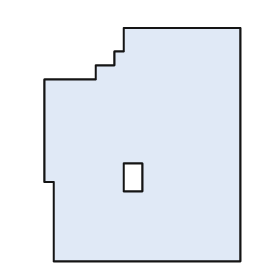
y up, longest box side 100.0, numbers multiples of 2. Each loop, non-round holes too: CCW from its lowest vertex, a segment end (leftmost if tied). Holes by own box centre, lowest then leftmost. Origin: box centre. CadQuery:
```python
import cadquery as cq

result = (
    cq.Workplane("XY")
    .moveTo(-38.0, -50.0)
    .lineTo(42.0, -50.0)
    .lineTo(42.0, 50.0)
    .lineTo(-8.0, 50.0)
    .lineTo(-8.0, 40.0)
    .lineTo(-12.0, 40.0)
    .lineTo(-12.0, 34.0)
    .lineTo(-20.0, 34.0)
    .lineTo(-20.0, 28.0)
    .lineTo(-42.0, 28.0)
    .lineTo(-42.0, -16.0)
    .lineTo(-38.0, -16.0)
    .close()
    .moveTo(-8.0, -20.0)
    .lineTo(0.0, -20.0)
    .lineTo(0.0, -8.0)
    .lineTo(-8.0, -8.0)
    .close()
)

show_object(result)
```